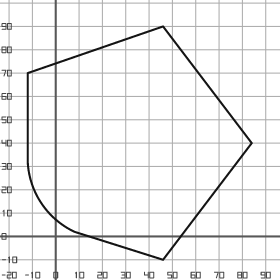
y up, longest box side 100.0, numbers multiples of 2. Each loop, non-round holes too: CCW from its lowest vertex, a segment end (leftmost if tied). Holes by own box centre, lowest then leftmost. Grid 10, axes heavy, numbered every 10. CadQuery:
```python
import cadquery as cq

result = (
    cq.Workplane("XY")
    .moveTo(46.0, -10.0)
    .lineTo(84.0, 40.0)
    .lineTo(46.0, 90.0)
    .lineTo(-12.0, 70.0)
    .lineTo(-12.0, 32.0)
    .threePointArc((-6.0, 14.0), (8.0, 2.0))
    .close()
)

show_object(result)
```